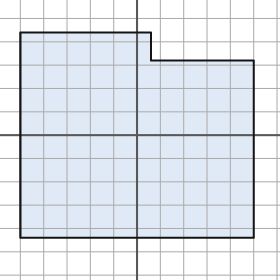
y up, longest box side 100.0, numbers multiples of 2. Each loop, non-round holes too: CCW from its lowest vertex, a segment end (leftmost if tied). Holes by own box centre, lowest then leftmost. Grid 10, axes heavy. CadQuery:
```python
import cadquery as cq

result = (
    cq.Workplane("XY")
    .moveTo(-50.0, -44.0)
    .lineTo(50.0, -44.0)
    .lineTo(50.0, 32.0)
    .lineTo(6.0, 32.0)
    .lineTo(6.0, 44.0)
    .lineTo(-50.0, 44.0)
    .close()
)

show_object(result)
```